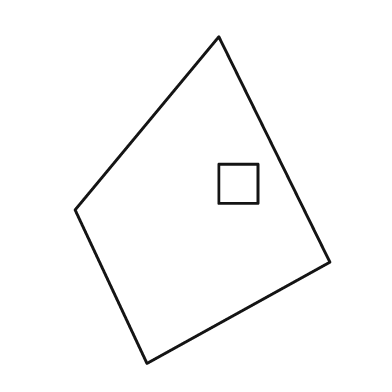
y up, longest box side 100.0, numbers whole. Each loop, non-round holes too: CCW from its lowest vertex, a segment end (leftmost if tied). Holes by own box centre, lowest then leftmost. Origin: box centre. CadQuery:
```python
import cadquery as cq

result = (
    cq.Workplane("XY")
    .moveTo(-17.0, -50.0)
    .lineTo(39.0, -19.0)
    .lineTo(5.0, 50.0)
    .lineTo(-39.0, -3.0)
    .close()
    .moveTo(5.0, -1.0)
    .lineTo(17.0, -1.0)
    .lineTo(17.0, 11.0)
    .lineTo(5.0, 11.0)
    .close()
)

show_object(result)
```